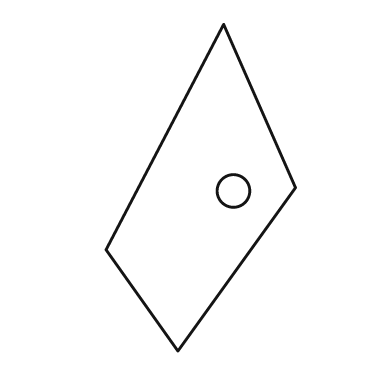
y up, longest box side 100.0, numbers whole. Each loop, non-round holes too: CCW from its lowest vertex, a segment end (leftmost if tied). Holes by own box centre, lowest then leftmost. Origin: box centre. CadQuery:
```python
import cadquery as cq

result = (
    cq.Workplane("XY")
    .moveTo(-7.0, -50.0)
    .lineTo(29.0, 0.0)
    .lineTo(7.0, 50.0)
    .lineTo(-29.0, -19.0)
    .close()
    .moveTo(10.0, -1.0)
    .circle(5.0)
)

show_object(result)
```